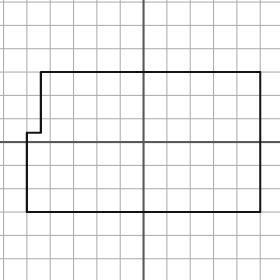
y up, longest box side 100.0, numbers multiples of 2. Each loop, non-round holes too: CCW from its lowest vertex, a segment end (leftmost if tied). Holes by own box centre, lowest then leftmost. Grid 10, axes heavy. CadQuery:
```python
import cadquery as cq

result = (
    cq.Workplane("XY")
    .moveTo(-50.0, -30.0)
    .lineTo(50.0, -30.0)
    .lineTo(50.0, 30.0)
    .lineTo(-44.0, 30.0)
    .lineTo(-44.0, 4.0)
    .lineTo(-50.0, 4.0)
    .close()
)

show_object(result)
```